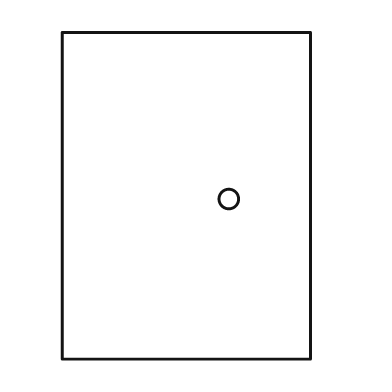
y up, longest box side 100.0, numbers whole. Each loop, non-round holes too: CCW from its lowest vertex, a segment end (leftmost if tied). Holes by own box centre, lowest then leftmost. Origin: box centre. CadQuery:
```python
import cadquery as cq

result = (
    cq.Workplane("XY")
    .moveTo(-38.0, -50.0)
    .lineTo(38.0, -50.0)
    .lineTo(38.0, 50.0)
    .lineTo(-38.0, 50.0)
    .close()
    .moveTo(13.0, -1.0)
    .circle(3.0)
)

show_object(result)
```